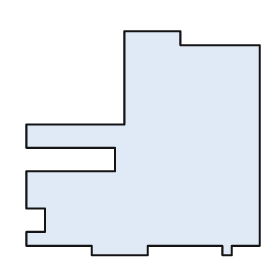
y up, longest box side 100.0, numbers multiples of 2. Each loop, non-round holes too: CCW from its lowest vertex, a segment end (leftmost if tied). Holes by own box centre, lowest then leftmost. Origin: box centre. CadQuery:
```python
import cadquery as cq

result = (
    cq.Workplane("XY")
    .moveTo(-22.0, -48.0)
    .lineTo(2.0, -48.0)
    .lineTo(2.0, -44.0)
    .lineTo(34.0, -44.0)
    .lineTo(34.0, -48.0)
    .lineTo(38.0, -48.0)
    .lineTo(38.0, -44.0)
    .lineTo(50.0, -44.0)
    .lineTo(50.0, 42.0)
    .lineTo(16.0, 42.0)
    .lineTo(16.0, 48.0)
    .lineTo(-8.0, 48.0)
    .lineTo(-8.0, 8.0)
    .lineTo(-50.0, 8.0)
    .lineTo(-50.0, -2.0)
    .lineTo(-12.0, -2.0)
    .lineTo(-12.0, -12.0)
    .lineTo(-50.0, -12.0)
    .lineTo(-50.0, -28.0)
    .lineTo(-42.0, -28.0)
    .lineTo(-42.0, -38.0)
    .lineTo(-50.0, -38.0)
    .lineTo(-50.0, -44.0)
    .lineTo(-22.0, -44.0)
    .close()
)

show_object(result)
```